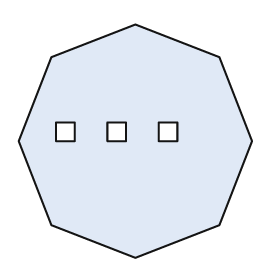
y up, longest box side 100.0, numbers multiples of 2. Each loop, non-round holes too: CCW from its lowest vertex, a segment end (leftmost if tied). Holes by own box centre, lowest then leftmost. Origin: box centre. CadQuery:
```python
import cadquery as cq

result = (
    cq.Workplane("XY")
    .moveTo(0.0, -50.0)
    .lineTo(36.0, -36.0)
    .lineTo(50.0, 0.0)
    .lineTo(36.0, 36.0)
    .lineTo(0.0, 50.0)
    .lineTo(-36.0, 36.0)
    .lineTo(-50.0, 0.0)
    .lineTo(-36.0, -36.0)
    .close()
    .moveTo(-34.0, 0.0)
    .lineTo(-26.0, 0.0)
    .lineTo(-26.0, 8.0)
    .lineTo(-34.0, 8.0)
    .close()
    .moveTo(-12.0, 0.0)
    .lineTo(-4.0, 0.0)
    .lineTo(-4.0, 8.0)
    .lineTo(-12.0, 8.0)
    .close()
    .moveTo(10.0, 0.0)
    .lineTo(18.0, 0.0)
    .lineTo(18.0, 8.0)
    .lineTo(10.0, 8.0)
    .close()
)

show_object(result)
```